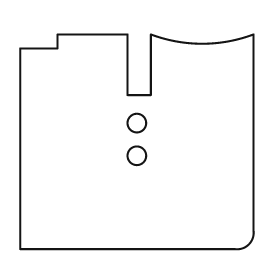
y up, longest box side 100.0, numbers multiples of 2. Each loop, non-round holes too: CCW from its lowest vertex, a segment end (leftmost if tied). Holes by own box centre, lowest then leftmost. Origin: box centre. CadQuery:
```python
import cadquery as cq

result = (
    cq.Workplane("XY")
    .moveTo(-50.0, -46.0)
    .lineTo(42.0, -46.0)
    .threePointArc((48.0, -44.0), (50.0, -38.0))
    .lineTo(50.0, 46.0)
    .threePointArc((28.0, 42.0), (6.0, 46.0))
    .lineTo(6.0, 20.0)
    .lineTo(-4.0, 20.0)
    .lineTo(-4.0, 46.0)
    .lineTo(-34.0, 46.0)
    .lineTo(-34.0, 40.0)
    .lineTo(-50.0, 40.0)
    .close()
    .moveTo(0.0, -6.0)
    .circle(4.0)
    .moveTo(0.0, 8.0)
    .circle(4.0)
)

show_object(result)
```